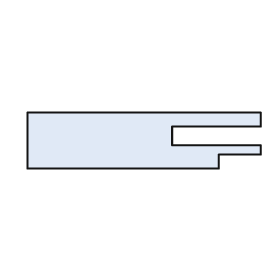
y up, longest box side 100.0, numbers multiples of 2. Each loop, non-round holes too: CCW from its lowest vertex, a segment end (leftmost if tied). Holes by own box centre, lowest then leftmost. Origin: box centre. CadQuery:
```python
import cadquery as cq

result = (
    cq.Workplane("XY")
    .moveTo(-50.0, -12.0)
    .lineTo(32.0, -12.0)
    .lineTo(32.0, -6.0)
    .lineTo(50.0, -6.0)
    .lineTo(50.0, -2.0)
    .lineTo(12.0, -2.0)
    .lineTo(12.0, 6.0)
    .lineTo(50.0, 6.0)
    .lineTo(50.0, 12.0)
    .lineTo(-50.0, 12.0)
    .close()
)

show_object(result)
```